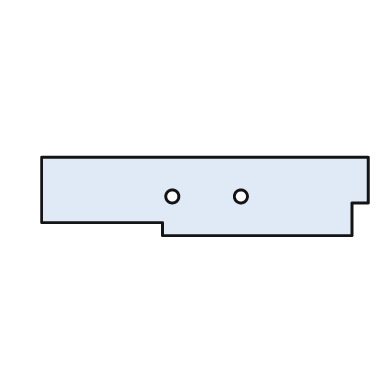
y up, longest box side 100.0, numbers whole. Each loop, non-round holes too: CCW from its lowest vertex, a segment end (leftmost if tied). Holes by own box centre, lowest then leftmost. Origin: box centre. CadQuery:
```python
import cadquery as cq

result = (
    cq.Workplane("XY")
    .moveTo(-13.0, -12.0)
    .lineTo(45.0, -12.0)
    .lineTo(45.0, -2.0)
    .lineTo(50.0, -2.0)
    .lineTo(50.0, 12.0)
    .lineTo(-50.0, 12.0)
    .lineTo(-50.0, -8.0)
    .lineTo(-13.0, -8.0)
    .close()
    .moveTo(-10.0, 0.0)
    .circle(2.0)
    .moveTo(11.0, 0.0)
    .circle(2.0)
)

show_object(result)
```